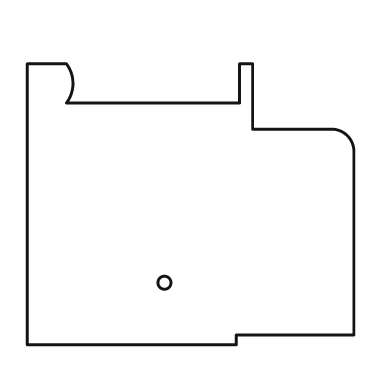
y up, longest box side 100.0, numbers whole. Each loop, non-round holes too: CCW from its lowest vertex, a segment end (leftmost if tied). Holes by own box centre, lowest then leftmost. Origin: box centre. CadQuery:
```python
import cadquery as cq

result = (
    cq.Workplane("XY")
    .moveTo(-50.0, -43.0)
    .lineTo(14.0, -43.0)
    .lineTo(14.0, -40.0)
    .lineTo(50.0, -40.0)
    .lineTo(50.0, 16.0)
    .threePointArc((48.0, 21.0), (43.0, 23.0))
    .lineTo(19.0, 23.0)
    .lineTo(19.0, 43.0)
    .lineTo(15.0, 43.0)
    .lineTo(15.0, 31.0)
    .lineTo(-38.0, 31.0)
    .threePointArc((-36.0, 37.0), (-38.0, 43.0))
    .lineTo(-50.0, 43.0)
    .close()
    .moveTo(-8.0, -24.0)
    .circle(2.0)
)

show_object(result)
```